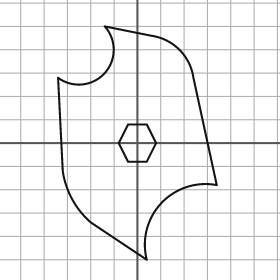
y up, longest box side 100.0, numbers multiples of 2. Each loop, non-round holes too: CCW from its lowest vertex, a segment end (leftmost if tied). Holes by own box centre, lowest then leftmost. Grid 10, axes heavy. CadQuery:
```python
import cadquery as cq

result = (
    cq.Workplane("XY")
    .moveTo(4.0, -50.0)
    .threePointArc((10.0, -26.0), (34.0, -18.0))
    .lineTo(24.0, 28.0)
    .threePointArc((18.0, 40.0), (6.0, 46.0))
    .lineTo(-14.0, 50.0)
    .threePointArc((-14.0, 30.0), (-34.0, 28.0))
    .lineTo(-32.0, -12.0)
    .threePointArc((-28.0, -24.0), (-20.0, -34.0))
    .close()
    .moveTo(-4.0, -8.0)
    .lineTo(4.0, -8.0)
    .lineTo(8.0, 0.0)
    .lineTo(4.0, 8.0)
    .lineTo(-4.0, 8.0)
    .lineTo(-8.0, 0.0)
    .close()
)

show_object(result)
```